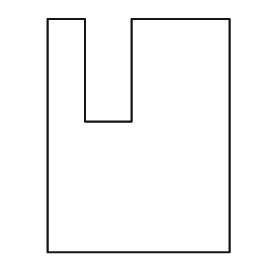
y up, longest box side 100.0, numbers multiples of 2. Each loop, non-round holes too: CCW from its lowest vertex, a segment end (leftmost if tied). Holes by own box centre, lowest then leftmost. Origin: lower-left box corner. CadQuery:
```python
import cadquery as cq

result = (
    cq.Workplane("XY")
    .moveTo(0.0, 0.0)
    .lineTo(78.0, 0.0)
    .lineTo(78.0, 100.0)
    .lineTo(36.0, 100.0)
    .lineTo(36.0, 56.0)
    .lineTo(16.0, 56.0)
    .lineTo(16.0, 100.0)
    .lineTo(0.0, 100.0)
    .close()
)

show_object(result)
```